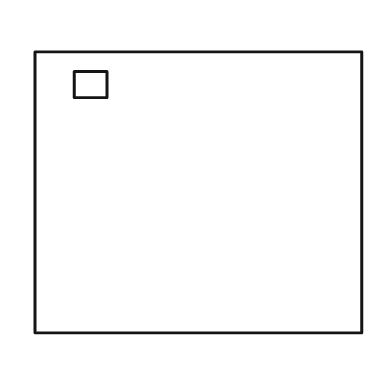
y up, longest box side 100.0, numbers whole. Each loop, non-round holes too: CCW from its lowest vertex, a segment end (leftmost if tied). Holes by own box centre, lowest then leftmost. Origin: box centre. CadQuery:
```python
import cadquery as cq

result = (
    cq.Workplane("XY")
    .moveTo(-50.0, -43.0)
    .lineTo(50.0, -43.0)
    .lineTo(50.0, 43.0)
    .lineTo(-50.0, 43.0)
    .close()
    .moveTo(-38.0, 29.0)
    .lineTo(-28.0, 29.0)
    .lineTo(-28.0, 37.0)
    .lineTo(-38.0, 37.0)
    .close()
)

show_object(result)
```